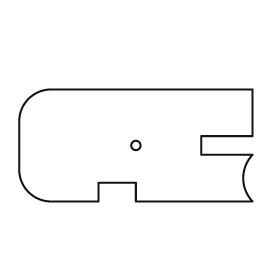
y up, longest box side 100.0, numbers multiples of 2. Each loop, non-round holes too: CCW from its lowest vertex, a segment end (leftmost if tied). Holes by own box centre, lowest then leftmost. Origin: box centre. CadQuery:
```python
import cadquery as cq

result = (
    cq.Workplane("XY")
    .moveTo(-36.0, -24.0)
    .lineTo(-16.0, -24.0)
    .lineTo(-16.0, -16.0)
    .lineTo(0.0, -16.0)
    .lineTo(0.0, -24.0)
    .lineTo(50.0, -24.0)
    .threePointArc((46.0, -14.0), (50.0, -4.0))
    .lineTo(28.0, -4.0)
    .lineTo(28.0, 4.0)
    .lineTo(50.0, 4.0)
    .lineTo(50.0, 24.0)
    .lineTo(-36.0, 24.0)
    .threePointArc((-46.0, 20.0), (-50.0, 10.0))
    .lineTo(-50.0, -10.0)
    .threePointArc((-46.0, -20.0), (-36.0, -24.0))
    .close()
    .moveTo(0.0, 0.0)
    .circle(2.0)
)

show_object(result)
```